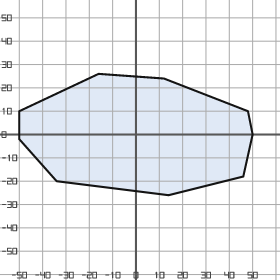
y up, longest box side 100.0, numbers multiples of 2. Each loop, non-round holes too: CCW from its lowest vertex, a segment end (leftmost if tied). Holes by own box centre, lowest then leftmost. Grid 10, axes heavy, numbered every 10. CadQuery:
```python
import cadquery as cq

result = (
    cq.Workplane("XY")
    .moveTo(14.0, -26.0)
    .lineTo(46.0, -18.0)
    .lineTo(50.0, 0.0)
    .lineTo(48.0, 10.0)
    .lineTo(12.0, 24.0)
    .lineTo(-16.0, 26.0)
    .lineTo(-50.0, 10.0)
    .lineTo(-50.0, -2.0)
    .lineTo(-34.0, -20.0)
    .close()
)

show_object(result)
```